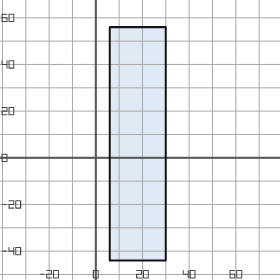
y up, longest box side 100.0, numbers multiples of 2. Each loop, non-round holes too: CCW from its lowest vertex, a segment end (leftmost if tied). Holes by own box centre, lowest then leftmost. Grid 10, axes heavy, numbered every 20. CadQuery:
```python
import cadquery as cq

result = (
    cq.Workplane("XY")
    .moveTo(6.0, -44.0)
    .lineTo(30.0, -44.0)
    .lineTo(30.0, 56.0)
    .lineTo(6.0, 56.0)
    .close()
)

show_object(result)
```